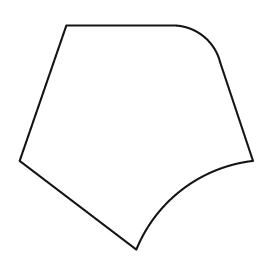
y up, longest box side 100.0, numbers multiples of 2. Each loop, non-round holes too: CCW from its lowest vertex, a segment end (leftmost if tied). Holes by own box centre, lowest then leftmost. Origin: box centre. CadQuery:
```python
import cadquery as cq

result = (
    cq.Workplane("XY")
    .moveTo(0.0, -48.0)
    .threePointArc((20.0, -22.0), (50.0, -10.0))
    .lineTo(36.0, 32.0)
    .threePointArc((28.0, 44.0), (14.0, 48.0))
    .lineTo(-30.0, 48.0)
    .lineTo(-50.0, -10.0)
    .close()
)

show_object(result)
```